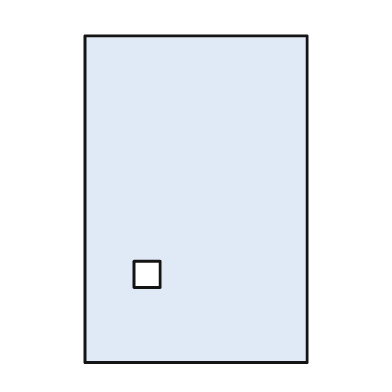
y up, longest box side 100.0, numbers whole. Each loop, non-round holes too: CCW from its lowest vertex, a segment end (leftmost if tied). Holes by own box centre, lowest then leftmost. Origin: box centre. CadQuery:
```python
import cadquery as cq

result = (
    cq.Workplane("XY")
    .moveTo(-34.0, -50.0)
    .lineTo(34.0, -50.0)
    .lineTo(34.0, 50.0)
    .lineTo(-34.0, 50.0)
    .close()
    .moveTo(-19.0, -27.0)
    .lineTo(-11.0, -27.0)
    .lineTo(-11.0, -19.0)
    .lineTo(-19.0, -19.0)
    .close()
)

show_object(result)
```